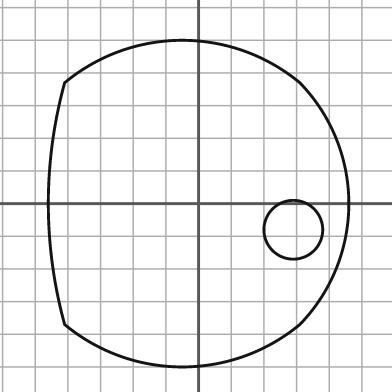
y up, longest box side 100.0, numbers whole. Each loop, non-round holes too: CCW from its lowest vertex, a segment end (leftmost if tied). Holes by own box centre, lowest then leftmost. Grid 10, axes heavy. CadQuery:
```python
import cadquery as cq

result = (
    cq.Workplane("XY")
    .moveTo(-41.0, -37.0)
    .threePointArc((-5.0, -50.0), (31.0, -37.0))
    .threePointArc((46.0, 0.0), (31.0, 37.0))
    .threePointArc((-5.0, 50.0), (-41.0, 37.0))
    .threePointArc((-46.0, 0.0), (-41.0, -37.0))
    .close()
    .moveTo(29.0, -8.0)
    .circle(9.0)
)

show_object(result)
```